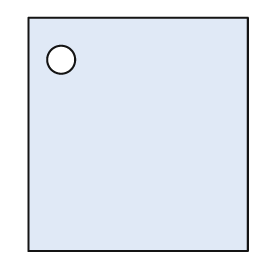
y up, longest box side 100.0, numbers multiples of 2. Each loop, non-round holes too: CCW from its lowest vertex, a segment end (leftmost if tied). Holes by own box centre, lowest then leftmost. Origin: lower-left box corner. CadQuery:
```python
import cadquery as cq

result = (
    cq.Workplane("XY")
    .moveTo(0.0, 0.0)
    .lineTo(94.0, 0.0)
    .lineTo(94.0, 100.0)
    .lineTo(0.0, 100.0)
    .close()
    .moveTo(14.0, 82.0)
    .circle(6.0)
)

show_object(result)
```